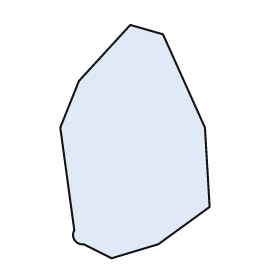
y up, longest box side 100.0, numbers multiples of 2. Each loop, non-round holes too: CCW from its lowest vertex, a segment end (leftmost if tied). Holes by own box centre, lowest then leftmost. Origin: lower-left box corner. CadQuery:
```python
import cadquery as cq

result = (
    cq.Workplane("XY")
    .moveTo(22.0, 0.0)
    .lineTo(42.0, 6.0)
    .lineTo(64.0, 22.0)
    .lineTo(62.0, 56.0)
    .lineTo(44.0, 96.0)
    .lineTo(30.0, 100.0)
    .lineTo(8.0, 76.0)
    .lineTo(0.0, 56.0)
    .lineTo(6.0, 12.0)
    .threePointArc((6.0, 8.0), (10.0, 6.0))
    .close()
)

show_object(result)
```